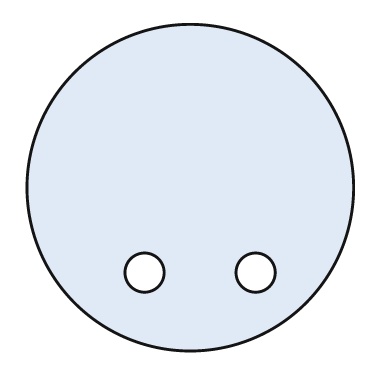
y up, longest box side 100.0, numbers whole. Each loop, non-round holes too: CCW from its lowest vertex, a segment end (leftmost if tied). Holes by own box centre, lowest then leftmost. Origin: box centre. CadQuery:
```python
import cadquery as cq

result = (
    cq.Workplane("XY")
    .moveTo(0.0, 0.0)
    .circle(50.0)
    .moveTo(-14.0, -26.0)
    .circle(6.0)
    .moveTo(20.0, -26.0)
    .circle(6.0)
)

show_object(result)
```